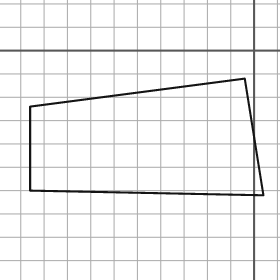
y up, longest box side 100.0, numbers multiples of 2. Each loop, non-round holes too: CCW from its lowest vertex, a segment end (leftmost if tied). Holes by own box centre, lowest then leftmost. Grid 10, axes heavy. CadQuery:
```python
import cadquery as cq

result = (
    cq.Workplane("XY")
    .moveTo(4.0, -62.0)
    .lineTo(-4.0, -12.0)
    .lineTo(-96.0, -24.0)
    .lineTo(-96.0, -60.0)
    .close()
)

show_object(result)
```